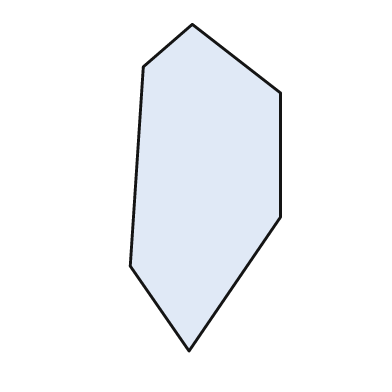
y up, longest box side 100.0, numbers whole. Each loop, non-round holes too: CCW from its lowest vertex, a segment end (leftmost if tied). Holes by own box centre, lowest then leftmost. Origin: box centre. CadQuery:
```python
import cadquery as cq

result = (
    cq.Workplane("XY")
    .moveTo(-5.0, -50.0)
    .lineTo(23.0, -9.0)
    .lineTo(23.0, 29.0)
    .lineTo(-4.0, 50.0)
    .lineTo(-19.0, 37.0)
    .lineTo(-23.0, -24.0)
    .close()
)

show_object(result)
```